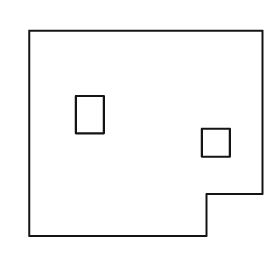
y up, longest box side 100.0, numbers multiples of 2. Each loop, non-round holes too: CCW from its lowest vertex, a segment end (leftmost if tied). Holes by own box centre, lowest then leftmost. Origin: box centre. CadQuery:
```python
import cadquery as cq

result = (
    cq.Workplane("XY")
    .moveTo(-50.0, -44.0)
    .lineTo(26.0, -44.0)
    .lineTo(26.0, -26.0)
    .lineTo(50.0, -26.0)
    .lineTo(50.0, 44.0)
    .lineTo(-50.0, 44.0)
    .close()
    .moveTo(24.0, -10.0)
    .lineTo(36.0, -10.0)
    .lineTo(36.0, 2.0)
    .lineTo(24.0, 2.0)
    .close()
    .moveTo(-30.0, 0.0)
    .lineTo(-18.0, 0.0)
    .lineTo(-18.0, 16.0)
    .lineTo(-30.0, 16.0)
    .close()
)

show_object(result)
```